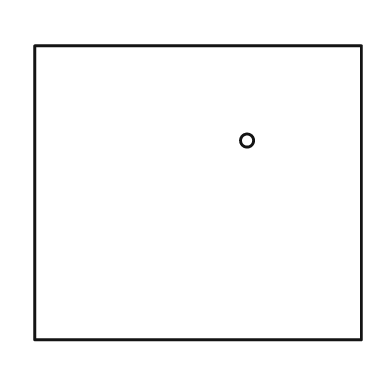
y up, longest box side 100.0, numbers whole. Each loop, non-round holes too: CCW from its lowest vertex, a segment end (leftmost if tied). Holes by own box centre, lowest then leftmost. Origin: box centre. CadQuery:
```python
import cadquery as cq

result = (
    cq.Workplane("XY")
    .moveTo(-50.0, -45.0)
    .lineTo(50.0, -45.0)
    .lineTo(50.0, 45.0)
    .lineTo(-50.0, 45.0)
    .close()
    .moveTo(15.0, 16.0)
    .circle(2.0)
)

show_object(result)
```